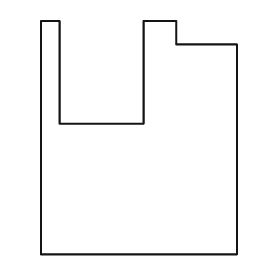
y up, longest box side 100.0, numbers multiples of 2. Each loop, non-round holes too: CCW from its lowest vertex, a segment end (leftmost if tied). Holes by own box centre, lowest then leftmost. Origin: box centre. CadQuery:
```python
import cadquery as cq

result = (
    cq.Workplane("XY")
    .moveTo(-42.0, -50.0)
    .lineTo(42.0, -50.0)
    .lineTo(42.0, 40.0)
    .lineTo(16.0, 40.0)
    .lineTo(16.0, 50.0)
    .lineTo(2.0, 50.0)
    .lineTo(2.0, 6.0)
    .lineTo(-34.0, 6.0)
    .lineTo(-34.0, 50.0)
    .lineTo(-42.0, 50.0)
    .close()
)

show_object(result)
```